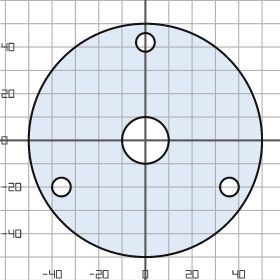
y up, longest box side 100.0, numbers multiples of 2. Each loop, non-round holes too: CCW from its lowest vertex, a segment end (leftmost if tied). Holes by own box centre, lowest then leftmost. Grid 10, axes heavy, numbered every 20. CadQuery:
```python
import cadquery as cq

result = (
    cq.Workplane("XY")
    .moveTo(0.0, 0.0)
    .circle(50.0)
    .moveTo(-36.0, -20.0)
    .circle(4.0)
    .moveTo(36.0, -20.0)
    .circle(4.0)
    .moveTo(0.0, 0.0)
    .circle(10.0)
    .moveTo(0.0, 42.0)
    .circle(4.0)
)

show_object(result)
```